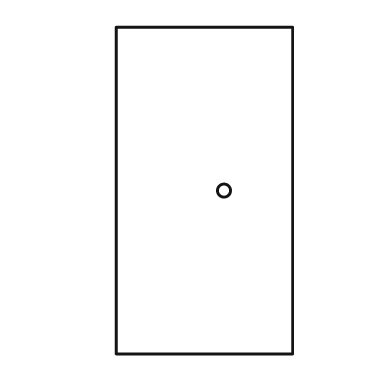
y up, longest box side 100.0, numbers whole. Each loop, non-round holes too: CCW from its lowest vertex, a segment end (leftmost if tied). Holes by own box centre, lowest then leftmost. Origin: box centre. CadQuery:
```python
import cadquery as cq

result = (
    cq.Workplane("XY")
    .moveTo(-27.0, -50.0)
    .lineTo(27.0, -50.0)
    .lineTo(27.0, 50.0)
    .lineTo(-27.0, 50.0)
    .close()
    .moveTo(6.0, 0.0)
    .circle(2.0)
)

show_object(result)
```